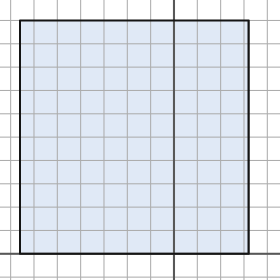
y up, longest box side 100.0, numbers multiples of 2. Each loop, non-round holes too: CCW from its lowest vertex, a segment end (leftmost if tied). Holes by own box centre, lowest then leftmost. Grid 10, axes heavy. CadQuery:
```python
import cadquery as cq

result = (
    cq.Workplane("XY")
    .moveTo(-66.0, 0.0)
    .lineTo(32.0, 0.0)
    .lineTo(32.0, 100.0)
    .lineTo(-66.0, 100.0)
    .close()
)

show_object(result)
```